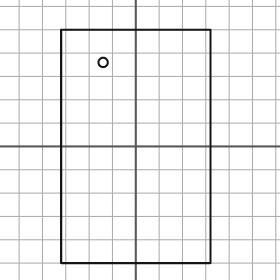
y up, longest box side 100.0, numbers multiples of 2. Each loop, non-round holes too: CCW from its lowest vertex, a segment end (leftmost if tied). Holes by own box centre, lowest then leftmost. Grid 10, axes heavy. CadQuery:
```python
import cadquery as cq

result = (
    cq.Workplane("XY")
    .moveTo(-32.0, -50.0)
    .lineTo(32.0, -50.0)
    .lineTo(32.0, 50.0)
    .lineTo(-32.0, 50.0)
    .close()
    .moveTo(-14.0, 36.0)
    .circle(2.0)
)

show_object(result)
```